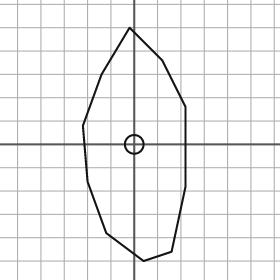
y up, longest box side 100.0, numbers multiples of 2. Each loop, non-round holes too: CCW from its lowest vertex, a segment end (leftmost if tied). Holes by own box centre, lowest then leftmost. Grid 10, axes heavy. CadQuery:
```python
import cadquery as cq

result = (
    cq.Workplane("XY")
    .moveTo(4.0, -50.0)
    .lineTo(16.0, -46.0)
    .lineTo(22.0, -18.0)
    .lineTo(22.0, 16.0)
    .lineTo(12.0, 36.0)
    .lineTo(-2.0, 50.0)
    .lineTo(-14.0, 30.0)
    .lineTo(-22.0, 8.0)
    .lineTo(-20.0, -16.0)
    .lineTo(-12.0, -38.0)
    .close()
    .moveTo(0.0, 0.0)
    .circle(4.0)
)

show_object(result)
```